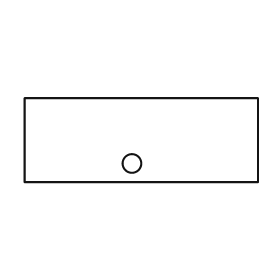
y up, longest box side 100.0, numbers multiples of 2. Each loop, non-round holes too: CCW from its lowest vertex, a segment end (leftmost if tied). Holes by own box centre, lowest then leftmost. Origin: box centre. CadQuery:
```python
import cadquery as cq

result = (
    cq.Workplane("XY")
    .moveTo(-50.0, -18.0)
    .lineTo(50.0, -18.0)
    .lineTo(50.0, 18.0)
    .lineTo(-50.0, 18.0)
    .close()
    .moveTo(-4.0, -10.0)
    .circle(4.0)
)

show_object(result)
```